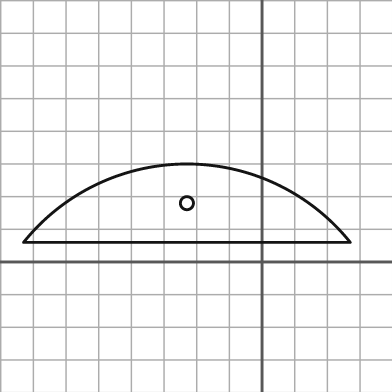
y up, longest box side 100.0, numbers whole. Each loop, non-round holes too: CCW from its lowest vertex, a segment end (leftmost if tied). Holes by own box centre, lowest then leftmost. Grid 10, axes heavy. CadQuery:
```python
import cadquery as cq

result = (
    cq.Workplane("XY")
    .moveTo(-73.0, 6.0)
    .lineTo(27.0, 6.0)
    .threePointArc((-23.0, 30.0), (-73.0, 6.0))
    .close()
    .moveTo(-23.0, 18.0)
    .circle(2.0)
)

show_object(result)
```